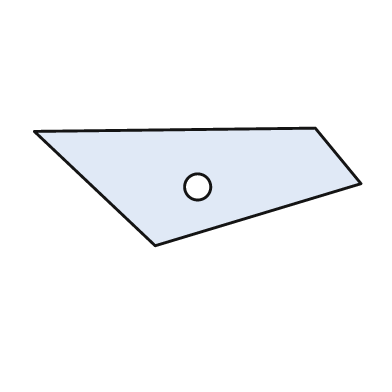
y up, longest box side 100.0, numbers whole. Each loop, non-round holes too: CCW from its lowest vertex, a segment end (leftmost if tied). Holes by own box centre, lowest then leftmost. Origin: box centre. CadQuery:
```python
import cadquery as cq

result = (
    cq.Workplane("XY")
    .moveTo(-13.0, -18.0)
    .lineTo(50.0, 1.0)
    .lineTo(36.0, 18.0)
    .lineTo(-50.0, 17.0)
    .close()
    .moveTo(0.0, 0.0)
    .circle(4.0)
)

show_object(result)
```